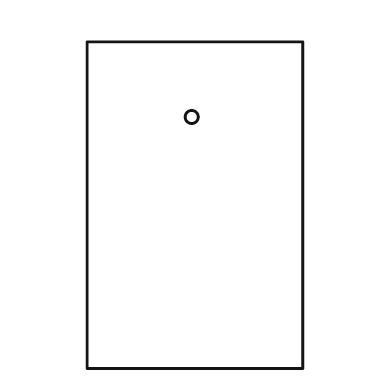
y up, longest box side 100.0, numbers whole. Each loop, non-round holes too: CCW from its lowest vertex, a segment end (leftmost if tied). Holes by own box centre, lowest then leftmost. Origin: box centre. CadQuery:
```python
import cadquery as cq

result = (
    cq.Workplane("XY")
    .moveTo(-33.0, -50.0)
    .lineTo(33.0, -50.0)
    .lineTo(33.0, 50.0)
    .lineTo(-33.0, 50.0)
    .close()
    .moveTo(-1.0, 27.0)
    .circle(2.0)
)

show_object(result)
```